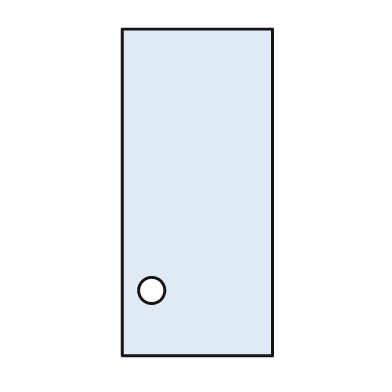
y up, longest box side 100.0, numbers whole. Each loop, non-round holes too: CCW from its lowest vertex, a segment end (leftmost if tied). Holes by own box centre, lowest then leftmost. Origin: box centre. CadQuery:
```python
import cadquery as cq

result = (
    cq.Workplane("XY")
    .moveTo(-23.0, -50.0)
    .lineTo(23.0, -50.0)
    .lineTo(23.0, 50.0)
    .lineTo(-23.0, 50.0)
    .close()
    .moveTo(-14.0, -30.0)
    .circle(4.0)
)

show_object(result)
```